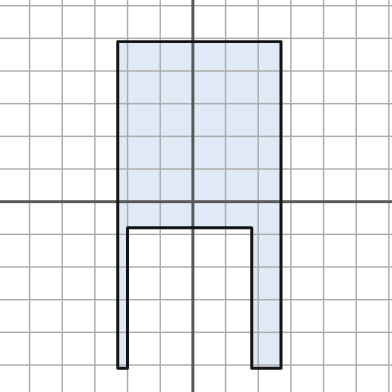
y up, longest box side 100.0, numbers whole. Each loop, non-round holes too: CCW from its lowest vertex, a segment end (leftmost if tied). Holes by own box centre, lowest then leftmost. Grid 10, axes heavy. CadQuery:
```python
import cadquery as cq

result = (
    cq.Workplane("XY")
    .moveTo(-23.0, -51.0)
    .lineTo(-20.0, -51.0)
    .lineTo(-20.0, -8.0)
    .lineTo(18.0, -8.0)
    .lineTo(18.0, -51.0)
    .lineTo(27.0, -51.0)
    .lineTo(27.0, 49.0)
    .lineTo(-23.0, 49.0)
    .close()
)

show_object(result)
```